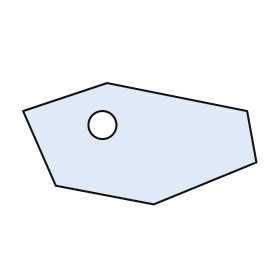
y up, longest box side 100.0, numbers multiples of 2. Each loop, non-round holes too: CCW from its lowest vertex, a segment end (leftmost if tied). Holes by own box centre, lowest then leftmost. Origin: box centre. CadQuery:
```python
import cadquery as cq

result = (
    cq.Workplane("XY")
    .moveTo(6.0, -26.0)
    .lineTo(50.0, -8.0)
    .lineTo(46.0, 14.0)
    .lineTo(-14.0, 26.0)
    .lineTo(-50.0, 14.0)
    .lineTo(-36.0, -18.0)
    .close()
    .moveTo(-16.0, 8.0)
    .circle(6.0)
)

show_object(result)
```